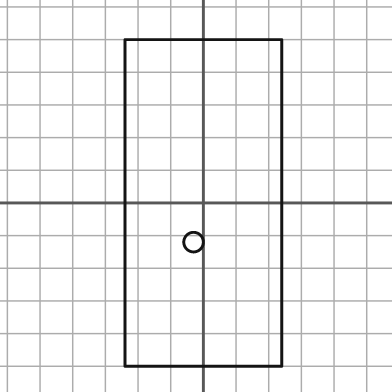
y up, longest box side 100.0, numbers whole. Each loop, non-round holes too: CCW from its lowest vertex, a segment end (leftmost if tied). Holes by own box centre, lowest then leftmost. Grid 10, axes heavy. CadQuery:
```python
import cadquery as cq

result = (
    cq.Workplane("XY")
    .moveTo(-24.0, -50.0)
    .lineTo(24.0, -50.0)
    .lineTo(24.0, 50.0)
    .lineTo(-24.0, 50.0)
    .close()
    .moveTo(-3.0, -12.0)
    .circle(3.0)
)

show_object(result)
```